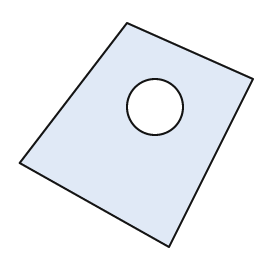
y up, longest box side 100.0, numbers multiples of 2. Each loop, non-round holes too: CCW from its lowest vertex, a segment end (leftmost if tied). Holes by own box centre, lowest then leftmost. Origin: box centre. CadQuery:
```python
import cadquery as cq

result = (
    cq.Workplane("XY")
    .moveTo(14.0, -48.0)
    .lineTo(50.0, 24.0)
    .lineTo(-4.0, 48.0)
    .lineTo(-50.0, -12.0)
    .close()
    .moveTo(8.0, 12.0)
    .circle(12.0)
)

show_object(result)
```